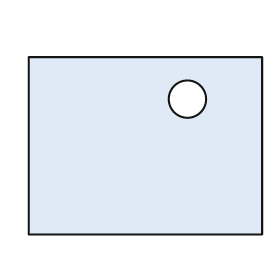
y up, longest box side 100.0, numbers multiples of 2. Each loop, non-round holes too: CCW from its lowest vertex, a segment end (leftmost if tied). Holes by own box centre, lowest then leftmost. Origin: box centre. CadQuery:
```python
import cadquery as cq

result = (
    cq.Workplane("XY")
    .moveTo(-50.0, -38.0)
    .lineTo(50.0, -38.0)
    .lineTo(50.0, 38.0)
    .lineTo(-50.0, 38.0)
    .close()
    .moveTo(18.0, 20.0)
    .circle(8.0)
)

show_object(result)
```